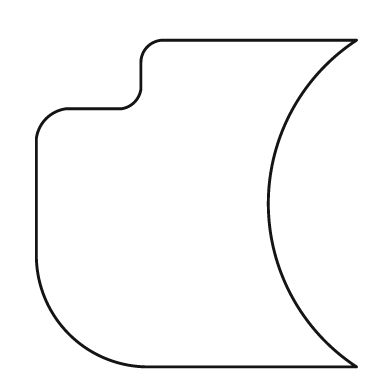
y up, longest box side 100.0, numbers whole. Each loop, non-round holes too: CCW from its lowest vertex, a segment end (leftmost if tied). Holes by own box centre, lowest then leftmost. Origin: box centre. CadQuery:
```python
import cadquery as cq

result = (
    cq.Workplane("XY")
    .moveTo(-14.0, -50.0)
    .lineTo(49.0, -50.0)
    .threePointArc((22.0, 0.0), (49.0, 50.0))
    .lineTo(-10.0, 50.0)
    .threePointArc((-15.0, 48.0), (-17.0, 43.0))
    .lineTo(-17.0, 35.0)
    .threePointArc((-19.0, 31.0), (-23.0, 29.0))
    .lineTo(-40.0, 29.0)
    .threePointArc((-46.0, 26.0), (-49.0, 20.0))
    .lineTo(-49.0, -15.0)
    .threePointArc((-39.0, -40.0), (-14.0, -50.0))
    .close()
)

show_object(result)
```